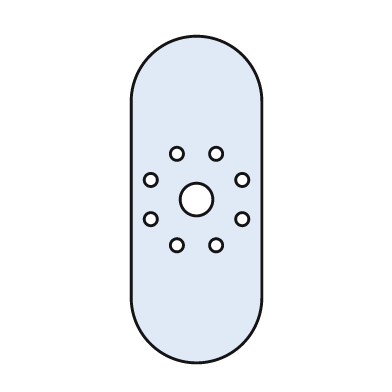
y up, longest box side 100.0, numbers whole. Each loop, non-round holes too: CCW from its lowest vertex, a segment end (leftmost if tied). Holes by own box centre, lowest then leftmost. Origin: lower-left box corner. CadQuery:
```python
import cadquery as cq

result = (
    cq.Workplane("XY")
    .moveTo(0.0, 20.0)
    .threePointArc((20.0, 0.0), (40.0, 20.0))
    .lineTo(40.0, 80.0)
    .threePointArc((20.0, 100.0), (0.0, 80.0))
    .close()
    .moveTo(14.0, 36.0)
    .circle(2.0)
    .moveTo(26.0, 36.0)
    .circle(2.0)
    .moveTo(6.0, 44.0)
    .circle(2.0)
    .moveTo(34.0, 44.0)
    .circle(2.0)
    .moveTo(20.0, 50.0)
    .circle(5.0)
    .moveTo(6.0, 56.0)
    .circle(2.0)
    .moveTo(34.0, 56.0)
    .circle(2.0)
    .moveTo(14.0, 64.0)
    .circle(2.0)
    .moveTo(26.0, 64.0)
    .circle(2.0)
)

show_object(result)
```